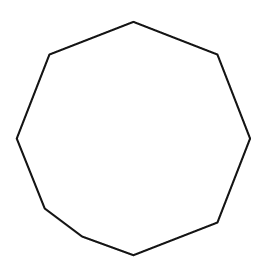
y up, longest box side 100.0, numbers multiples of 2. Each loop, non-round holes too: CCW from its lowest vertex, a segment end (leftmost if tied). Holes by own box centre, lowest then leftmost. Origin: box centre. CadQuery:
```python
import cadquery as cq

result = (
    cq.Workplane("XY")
    .moveTo(0.0, -50.0)
    .lineTo(36.0, -36.0)
    .lineTo(50.0, 0.0)
    .lineTo(36.0, 36.0)
    .lineTo(0.0, 50.0)
    .lineTo(-36.0, 36.0)
    .lineTo(-50.0, 0.0)
    .lineTo(-38.0, -30.0)
    .lineTo(-22.0, -42.0)
    .close()
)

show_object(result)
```